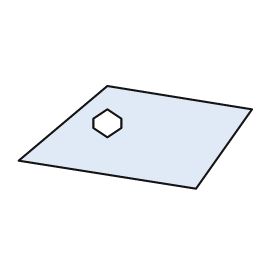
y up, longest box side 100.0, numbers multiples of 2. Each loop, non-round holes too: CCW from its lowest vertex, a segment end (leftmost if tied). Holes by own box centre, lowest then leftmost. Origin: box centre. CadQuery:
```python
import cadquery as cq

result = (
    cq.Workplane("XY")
    .moveTo(26.0, -22.0)
    .lineTo(50.0, 12.0)
    .lineTo(-12.0, 22.0)
    .lineTo(-50.0, -10.0)
    .close()
    .moveTo(-12.0, 0.0)
    .lineTo(-6.0, 4.0)
    .lineTo(-6.0, 8.0)
    .lineTo(-12.0, 12.0)
    .lineTo(-18.0, 8.0)
    .lineTo(-18.0, 4.0)
    .close()
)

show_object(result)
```